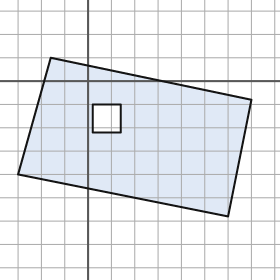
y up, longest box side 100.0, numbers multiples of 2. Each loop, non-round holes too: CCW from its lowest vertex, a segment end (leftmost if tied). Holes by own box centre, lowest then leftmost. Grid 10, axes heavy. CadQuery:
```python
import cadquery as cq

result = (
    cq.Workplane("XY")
    .moveTo(60.0, -58.0)
    .lineTo(70.0, -8.0)
    .lineTo(-16.0, 10.0)
    .lineTo(-30.0, -40.0)
    .close()
    .moveTo(2.0, -22.0)
    .lineTo(14.0, -22.0)
    .lineTo(14.0, -10.0)
    .lineTo(2.0, -10.0)
    .close()
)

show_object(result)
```